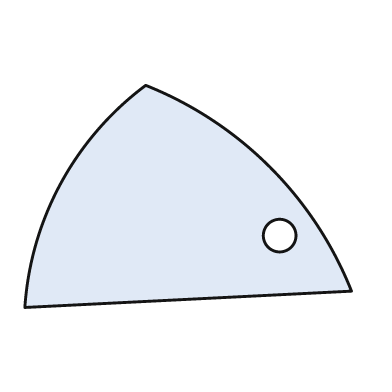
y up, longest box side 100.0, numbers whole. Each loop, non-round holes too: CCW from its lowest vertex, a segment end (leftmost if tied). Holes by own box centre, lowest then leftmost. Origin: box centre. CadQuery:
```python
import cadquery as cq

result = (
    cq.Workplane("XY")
    .moveTo(-50.0, -34.0)
    .lineTo(50.0, -29.0)
    .threePointArc((25.0, 9.0), (-13.0, 34.0))
    .threePointArc((-39.0, 4.0), (-50.0, -34.0))
    .close()
    .moveTo(28.0, -12.0)
    .circle(5.0)
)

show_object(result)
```